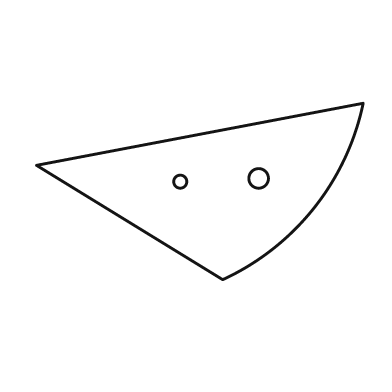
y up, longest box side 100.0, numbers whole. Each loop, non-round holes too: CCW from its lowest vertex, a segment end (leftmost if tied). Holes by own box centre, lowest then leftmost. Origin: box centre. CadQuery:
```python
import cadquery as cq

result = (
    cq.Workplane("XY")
    .moveTo(7.0, -27.0)
    .threePointArc((35.0, -5.0), (50.0, 27.0))
    .lineTo(-50.0, 8.0)
    .close()
    .moveTo(-6.0, 3.0)
    .circle(2.0)
    .moveTo(18.0, 4.0)
    .circle(3.0)
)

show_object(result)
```